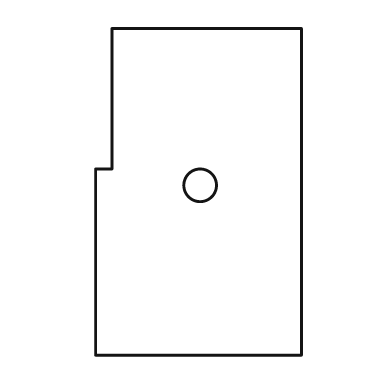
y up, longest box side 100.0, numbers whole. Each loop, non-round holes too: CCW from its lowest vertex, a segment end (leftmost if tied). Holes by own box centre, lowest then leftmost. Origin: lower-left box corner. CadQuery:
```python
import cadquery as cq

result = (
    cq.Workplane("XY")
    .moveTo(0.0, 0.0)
    .lineTo(63.0, 0.0)
    .lineTo(63.0, 100.0)
    .lineTo(5.0, 100.0)
    .lineTo(5.0, 57.0)
    .lineTo(0.0, 57.0)
    .close()
    .moveTo(32.0, 52.0)
    .circle(5.0)
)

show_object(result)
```